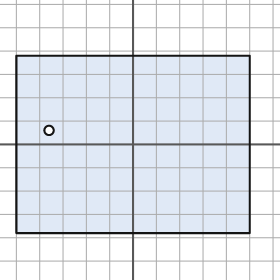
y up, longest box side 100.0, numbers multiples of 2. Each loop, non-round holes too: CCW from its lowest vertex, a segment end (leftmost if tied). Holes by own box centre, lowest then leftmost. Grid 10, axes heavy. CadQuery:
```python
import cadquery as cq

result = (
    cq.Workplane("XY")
    .moveTo(-50.0, -38.0)
    .lineTo(50.0, -38.0)
    .lineTo(50.0, 38.0)
    .lineTo(-50.0, 38.0)
    .close()
    .moveTo(-36.0, 6.0)
    .circle(2.0)
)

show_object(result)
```